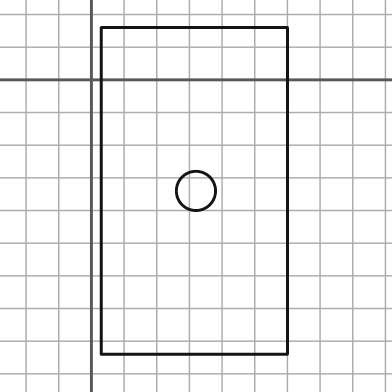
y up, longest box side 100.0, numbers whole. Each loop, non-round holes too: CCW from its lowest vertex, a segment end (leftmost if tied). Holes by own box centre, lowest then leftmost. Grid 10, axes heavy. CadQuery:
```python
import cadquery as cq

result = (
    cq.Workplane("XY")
    .moveTo(3.0, -84.0)
    .lineTo(60.0, -84.0)
    .lineTo(60.0, 16.0)
    .lineTo(3.0, 16.0)
    .close()
    .moveTo(32.0, -34.0)
    .circle(6.0)
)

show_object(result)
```